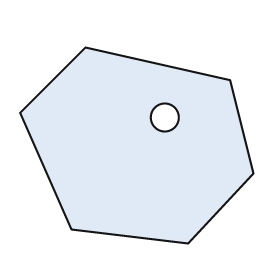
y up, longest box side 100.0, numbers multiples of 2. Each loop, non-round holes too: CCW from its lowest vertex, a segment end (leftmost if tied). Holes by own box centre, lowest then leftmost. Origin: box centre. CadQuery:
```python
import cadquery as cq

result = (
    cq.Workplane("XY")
    .moveTo(22.0, -42.0)
    .lineTo(50.0, -12.0)
    .lineTo(40.0, 28.0)
    .lineTo(-22.0, 42.0)
    .lineTo(-50.0, 14.0)
    .lineTo(-28.0, -36.0)
    .close()
    .moveTo(12.0, 12.0)
    .circle(6.0)
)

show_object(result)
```